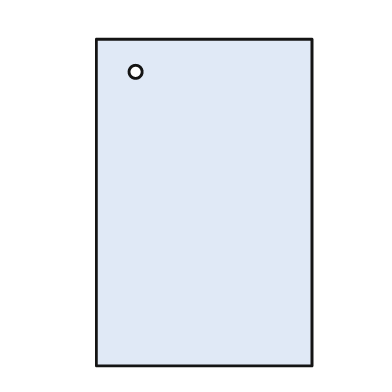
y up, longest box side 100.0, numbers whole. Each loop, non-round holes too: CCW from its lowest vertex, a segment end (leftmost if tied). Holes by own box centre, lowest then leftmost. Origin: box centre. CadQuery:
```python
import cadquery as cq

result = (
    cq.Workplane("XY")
    .moveTo(-33.0, -50.0)
    .lineTo(33.0, -50.0)
    .lineTo(33.0, 50.0)
    .lineTo(-33.0, 50.0)
    .close()
    .moveTo(-21.0, 40.0)
    .circle(2.0)
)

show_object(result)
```